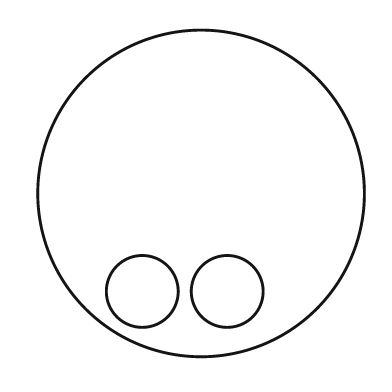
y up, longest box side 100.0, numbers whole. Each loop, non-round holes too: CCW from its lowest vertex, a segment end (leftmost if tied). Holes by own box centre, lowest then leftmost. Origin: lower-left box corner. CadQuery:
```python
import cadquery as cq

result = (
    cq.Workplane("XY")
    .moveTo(50.0, 50.0)
    .circle(50.0)
    .moveTo(32.0, 20.0)
    .circle(11.0)
    .moveTo(58.0, 20.0)
    .circle(11.0)
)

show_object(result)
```